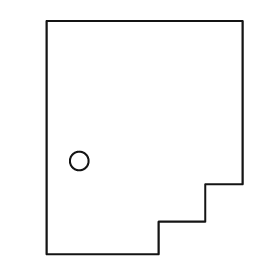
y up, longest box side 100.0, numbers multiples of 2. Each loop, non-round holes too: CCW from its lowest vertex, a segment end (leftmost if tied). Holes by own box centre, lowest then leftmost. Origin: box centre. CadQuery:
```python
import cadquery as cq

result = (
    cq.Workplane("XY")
    .moveTo(-42.0, -50.0)
    .lineTo(6.0, -50.0)
    .lineTo(6.0, -36.0)
    .lineTo(26.0, -36.0)
    .lineTo(26.0, -20.0)
    .lineTo(42.0, -20.0)
    .lineTo(42.0, 50.0)
    .lineTo(-42.0, 50.0)
    .close()
    .moveTo(-28.0, -10.0)
    .circle(4.0)
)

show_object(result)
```